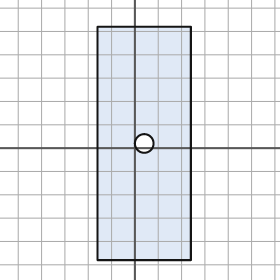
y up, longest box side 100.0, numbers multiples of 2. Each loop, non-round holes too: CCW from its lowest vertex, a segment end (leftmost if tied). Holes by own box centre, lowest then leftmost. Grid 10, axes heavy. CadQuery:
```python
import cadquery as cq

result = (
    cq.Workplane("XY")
    .moveTo(-16.0, -48.0)
    .lineTo(24.0, -48.0)
    .lineTo(24.0, 52.0)
    .lineTo(-16.0, 52.0)
    .close()
    .moveTo(4.0, 2.0)
    .circle(4.0)
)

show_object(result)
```